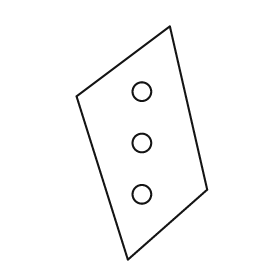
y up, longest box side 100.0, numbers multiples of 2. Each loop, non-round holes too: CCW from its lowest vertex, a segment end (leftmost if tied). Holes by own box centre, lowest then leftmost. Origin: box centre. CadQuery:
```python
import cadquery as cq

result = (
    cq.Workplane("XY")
    .moveTo(-6.0, -50.0)
    .lineTo(28.0, -20.0)
    .lineTo(12.0, 50.0)
    .lineTo(-28.0, 20.0)
    .close()
    .moveTo(0.0, -22.0)
    .circle(4.0)
    .moveTo(0.0, 0.0)
    .circle(4.0)
    .moveTo(0.0, 22.0)
    .circle(4.0)
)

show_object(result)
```